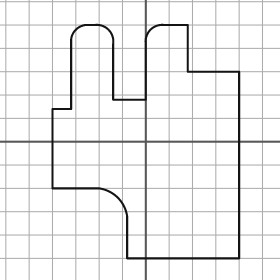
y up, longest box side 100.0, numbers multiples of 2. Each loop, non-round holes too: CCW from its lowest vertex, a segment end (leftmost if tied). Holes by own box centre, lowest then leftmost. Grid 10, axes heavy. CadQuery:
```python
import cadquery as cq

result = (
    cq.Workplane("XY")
    .moveTo(-8.0, -50.0)
    .lineTo(40.0, -50.0)
    .lineTo(40.0, 30.0)
    .lineTo(18.0, 30.0)
    .lineTo(18.0, 50.0)
    .lineTo(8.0, 50.0)
    .threePointArc((2.0, 48.0), (0.0, 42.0))
    .lineTo(0.0, 18.0)
    .lineTo(-14.0, 18.0)
    .lineTo(-14.0, 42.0)
    .threePointArc((-16.0, 48.0), (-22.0, 50.0))
    .lineTo(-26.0, 50.0)
    .threePointArc((-30.0, 48.0), (-32.0, 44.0))
    .lineTo(-32.0, 14.0)
    .lineTo(-40.0, 14.0)
    .lineTo(-40.0, -20.0)
    .lineTo(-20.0, -20.0)
    .threePointArc((-12.0, -24.0), (-8.0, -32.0))
    .close()
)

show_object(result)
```